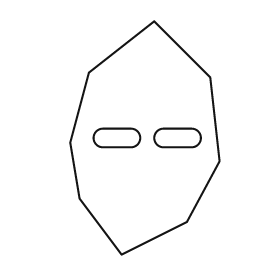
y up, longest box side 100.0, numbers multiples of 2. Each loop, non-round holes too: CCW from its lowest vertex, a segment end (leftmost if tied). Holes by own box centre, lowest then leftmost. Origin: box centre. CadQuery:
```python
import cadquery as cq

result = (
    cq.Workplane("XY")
    .moveTo(-10.0, -50.0)
    .lineTo(18.0, -36.0)
    .lineTo(32.0, -10.0)
    .lineTo(28.0, 26.0)
    .lineTo(4.0, 50.0)
    .lineTo(-24.0, 28.0)
    .lineTo(-32.0, -2.0)
    .lineTo(-28.0, -26.0)
    .close()
    .moveTo(-18.0, -4.0)
    .lineTo(-6.0, -4.0)
    .threePointArc((-2.0, 0.0), (-6.0, 4.0))
    .lineTo(-18.0, 4.0)
    .threePointArc((-22.0, 0.0), (-18.0, -4.0))
    .close()
    .moveTo(8.0, -4.0)
    .lineTo(20.0, -4.0)
    .threePointArc((24.0, 0.0), (20.0, 4.0))
    .lineTo(8.0, 4.0)
    .threePointArc((4.0, 0.0), (8.0, -4.0))
    .close()
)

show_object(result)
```